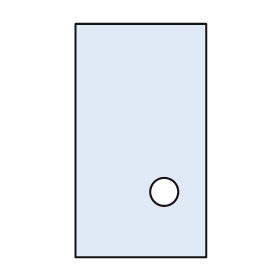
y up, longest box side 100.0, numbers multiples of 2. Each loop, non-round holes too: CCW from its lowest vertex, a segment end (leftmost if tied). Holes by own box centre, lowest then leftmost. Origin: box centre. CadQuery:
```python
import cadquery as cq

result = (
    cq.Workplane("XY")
    .moveTo(-28.0, -50.0)
    .lineTo(28.0, -50.0)
    .lineTo(28.0, 50.0)
    .lineTo(-28.0, 50.0)
    .close()
    .moveTo(10.0, -22.0)
    .circle(6.0)
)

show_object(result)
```